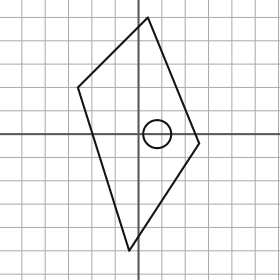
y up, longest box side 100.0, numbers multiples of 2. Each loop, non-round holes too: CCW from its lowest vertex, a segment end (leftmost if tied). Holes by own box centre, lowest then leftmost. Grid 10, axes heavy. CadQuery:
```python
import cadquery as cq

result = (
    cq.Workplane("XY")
    .moveTo(-4.0, -50.0)
    .lineTo(26.0, -4.0)
    .lineTo(4.0, 50.0)
    .lineTo(-26.0, 20.0)
    .close()
    .moveTo(8.0, 0.0)
    .circle(6.0)
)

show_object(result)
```